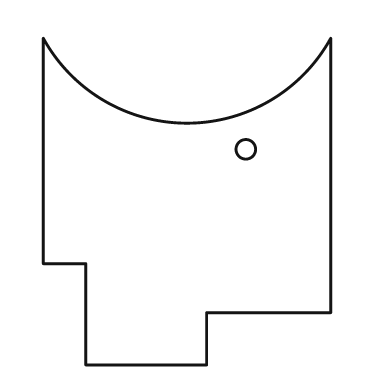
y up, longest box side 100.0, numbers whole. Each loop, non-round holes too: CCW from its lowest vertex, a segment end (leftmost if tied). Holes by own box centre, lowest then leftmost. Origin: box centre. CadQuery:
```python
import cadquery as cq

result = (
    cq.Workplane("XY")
    .moveTo(-31.0, -50.0)
    .lineTo(6.0, -50.0)
    .lineTo(6.0, -34.0)
    .lineTo(44.0, -34.0)
    .lineTo(44.0, 50.0)
    .threePointArc((0.0, 24.0), (-44.0, 50.0))
    .lineTo(-44.0, -19.0)
    .lineTo(-31.0, -19.0)
    .close()
    .moveTo(18.0, 16.0)
    .circle(3.0)
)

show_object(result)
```